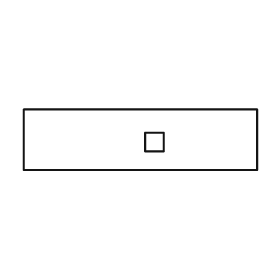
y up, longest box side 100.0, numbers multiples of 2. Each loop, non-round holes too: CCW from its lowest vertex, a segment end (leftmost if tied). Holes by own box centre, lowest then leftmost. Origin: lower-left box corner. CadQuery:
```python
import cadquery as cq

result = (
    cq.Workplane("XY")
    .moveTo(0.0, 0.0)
    .lineTo(100.0, 0.0)
    .lineTo(100.0, 26.0)
    .lineTo(0.0, 26.0)
    .close()
    .moveTo(52.0, 8.0)
    .lineTo(60.0, 8.0)
    .lineTo(60.0, 16.0)
    .lineTo(52.0, 16.0)
    .close()
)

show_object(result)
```